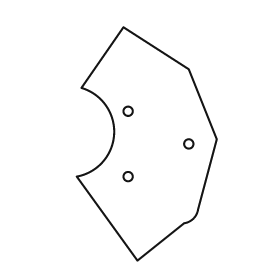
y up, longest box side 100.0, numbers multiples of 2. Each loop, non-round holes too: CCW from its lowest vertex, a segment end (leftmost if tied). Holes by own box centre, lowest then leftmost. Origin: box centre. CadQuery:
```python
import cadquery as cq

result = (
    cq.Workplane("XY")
    .moveTo(-4.0, -50.0)
    .lineTo(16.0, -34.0)
    .threePointArc((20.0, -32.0), (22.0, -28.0))
    .lineTo(30.0, 2.0)
    .lineTo(18.0, 32.0)
    .lineTo(-10.0, 50.0)
    .lineTo(-28.0, 24.0)
    .threePointArc((-14.0, 4.0), (-30.0, -14.0))
    .close()
    .moveTo(-8.0, -14.0)
    .circle(2.0)
    .moveTo(18.0, 0.0)
    .circle(2.0)
    .moveTo(-8.0, 14.0)
    .circle(2.0)
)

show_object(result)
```